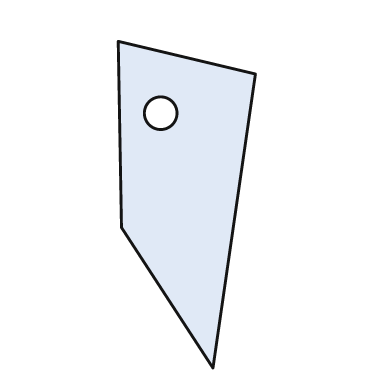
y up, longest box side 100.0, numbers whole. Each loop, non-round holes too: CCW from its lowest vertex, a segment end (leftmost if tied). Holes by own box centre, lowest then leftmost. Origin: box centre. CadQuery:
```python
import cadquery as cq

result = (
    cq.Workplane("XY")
    .moveTo(8.0, -50.0)
    .lineTo(21.0, 40.0)
    .lineTo(-21.0, 50.0)
    .lineTo(-20.0, -7.0)
    .close()
    .moveTo(-8.0, 28.0)
    .circle(5.0)
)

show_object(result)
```